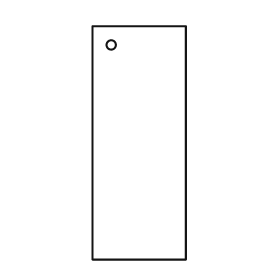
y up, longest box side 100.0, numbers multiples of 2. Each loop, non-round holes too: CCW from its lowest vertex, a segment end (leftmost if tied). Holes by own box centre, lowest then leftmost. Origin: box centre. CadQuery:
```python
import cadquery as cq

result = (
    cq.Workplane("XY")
    .moveTo(-20.0, -50.0)
    .lineTo(20.0, -50.0)
    .lineTo(20.0, 50.0)
    .lineTo(-20.0, 50.0)
    .close()
    .moveTo(-12.0, 42.0)
    .circle(2.0)
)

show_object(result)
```